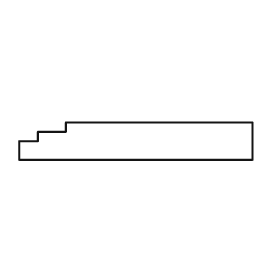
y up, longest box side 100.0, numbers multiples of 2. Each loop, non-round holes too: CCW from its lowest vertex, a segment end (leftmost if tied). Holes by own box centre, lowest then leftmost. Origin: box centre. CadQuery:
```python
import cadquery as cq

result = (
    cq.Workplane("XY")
    .moveTo(-50.0, -8.0)
    .lineTo(50.0, -8.0)
    .lineTo(50.0, 8.0)
    .lineTo(-30.0, 8.0)
    .lineTo(-30.0, 4.0)
    .lineTo(-42.0, 4.0)
    .lineTo(-42.0, 0.0)
    .lineTo(-50.0, 0.0)
    .close()
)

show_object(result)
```